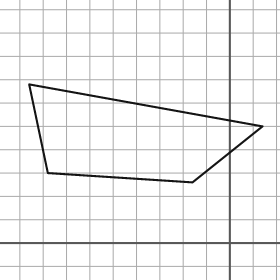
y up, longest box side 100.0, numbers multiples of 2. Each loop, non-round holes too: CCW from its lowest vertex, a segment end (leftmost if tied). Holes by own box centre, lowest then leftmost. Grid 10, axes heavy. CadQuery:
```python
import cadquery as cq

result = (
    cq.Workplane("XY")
    .moveTo(-16.0, 26.0)
    .lineTo(14.0, 50.0)
    .lineTo(-86.0, 68.0)
    .lineTo(-78.0, 30.0)
    .close()
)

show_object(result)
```